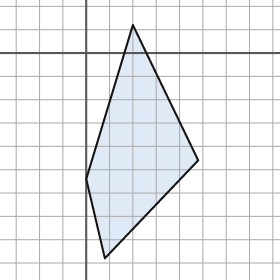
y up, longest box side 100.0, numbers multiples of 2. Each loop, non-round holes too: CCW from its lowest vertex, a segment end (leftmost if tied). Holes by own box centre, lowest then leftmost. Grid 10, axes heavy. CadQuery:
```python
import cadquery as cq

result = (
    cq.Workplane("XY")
    .moveTo(8.0, -88.0)
    .lineTo(48.0, -46.0)
    .lineTo(20.0, 12.0)
    .lineTo(0.0, -54.0)
    .close()
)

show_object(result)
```